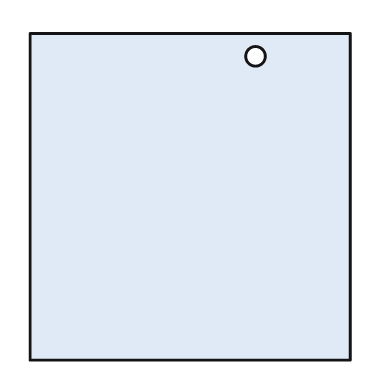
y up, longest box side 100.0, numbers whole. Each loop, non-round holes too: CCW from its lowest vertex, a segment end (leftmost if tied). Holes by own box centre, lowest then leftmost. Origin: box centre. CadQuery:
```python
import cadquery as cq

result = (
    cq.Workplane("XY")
    .moveTo(-49.0, -50.0)
    .lineTo(49.0, -50.0)
    .lineTo(49.0, 50.0)
    .lineTo(-49.0, 50.0)
    .close()
    .moveTo(20.0, 43.0)
    .circle(3.0)
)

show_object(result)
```